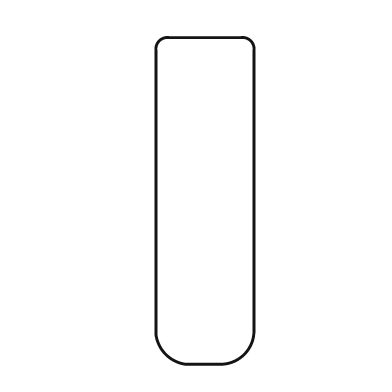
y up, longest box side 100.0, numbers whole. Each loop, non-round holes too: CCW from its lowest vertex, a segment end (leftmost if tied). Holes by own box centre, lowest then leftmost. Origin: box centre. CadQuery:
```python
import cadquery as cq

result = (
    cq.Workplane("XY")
    .moveTo(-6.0, -50.0)
    .lineTo(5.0, -50.0)
    .threePointArc((12.0, -47.0), (15.0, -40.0))
    .lineTo(15.0, 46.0)
    .threePointArc((14.0, 49.0), (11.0, 50.0))
    .lineTo(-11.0, 50.0)
    .threePointArc((-14.0, 49.0), (-15.0, 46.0))
    .lineTo(-15.0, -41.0)
    .threePointArc((-12.0, -47.0), (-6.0, -50.0))
    .close()
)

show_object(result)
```